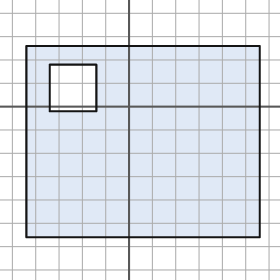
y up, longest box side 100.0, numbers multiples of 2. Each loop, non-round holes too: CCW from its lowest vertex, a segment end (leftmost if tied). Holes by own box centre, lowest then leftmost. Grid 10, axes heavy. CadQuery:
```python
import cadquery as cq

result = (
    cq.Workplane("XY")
    .moveTo(-44.0, -56.0)
    .lineTo(56.0, -56.0)
    .lineTo(56.0, 26.0)
    .lineTo(-44.0, 26.0)
    .close()
    .moveTo(-34.0, -2.0)
    .lineTo(-14.0, -2.0)
    .lineTo(-14.0, 18.0)
    .lineTo(-34.0, 18.0)
    .close()
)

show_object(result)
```